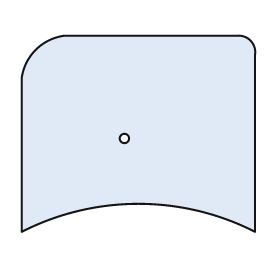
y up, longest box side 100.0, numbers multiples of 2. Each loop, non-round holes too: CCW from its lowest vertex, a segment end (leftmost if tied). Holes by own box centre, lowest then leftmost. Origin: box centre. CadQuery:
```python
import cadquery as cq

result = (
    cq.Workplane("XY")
    .moveTo(-50.0, -42.0)
    .threePointArc((0.0, -30.0), (50.0, -42.0))
    .lineTo(50.0, 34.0)
    .threePointArc((48.0, 40.0), (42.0, 42.0))
    .lineTo(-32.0, 42.0)
    .threePointArc((-44.0, 36.0), (-50.0, 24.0))
    .close()
    .moveTo(-6.0, -2.0)
    .circle(2.0)
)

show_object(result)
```